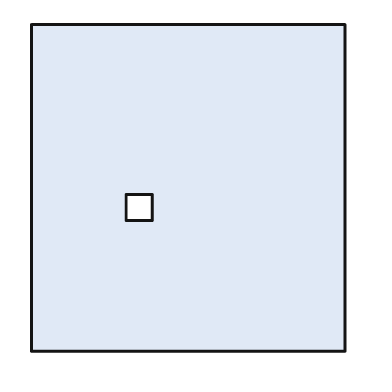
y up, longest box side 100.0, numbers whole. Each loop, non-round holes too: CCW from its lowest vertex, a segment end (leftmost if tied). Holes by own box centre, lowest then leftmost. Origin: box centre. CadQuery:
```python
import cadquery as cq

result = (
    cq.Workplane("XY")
    .moveTo(-48.0, -50.0)
    .lineTo(48.0, -50.0)
    .lineTo(48.0, 50.0)
    .lineTo(-48.0, 50.0)
    .close()
    .moveTo(-19.0, -10.0)
    .lineTo(-11.0, -10.0)
    .lineTo(-11.0, -2.0)
    .lineTo(-19.0, -2.0)
    .close()
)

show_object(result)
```